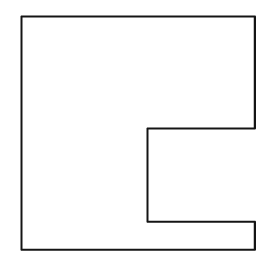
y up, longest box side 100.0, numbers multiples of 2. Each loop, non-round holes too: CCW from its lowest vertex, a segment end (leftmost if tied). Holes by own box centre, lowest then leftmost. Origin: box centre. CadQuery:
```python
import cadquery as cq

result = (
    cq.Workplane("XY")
    .moveTo(-50.0, -50.0)
    .lineTo(50.0, -50.0)
    .lineTo(50.0, -38.0)
    .lineTo(4.0, -38.0)
    .lineTo(4.0, 2.0)
    .lineTo(50.0, 2.0)
    .lineTo(50.0, 50.0)
    .lineTo(-50.0, 50.0)
    .close()
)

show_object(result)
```